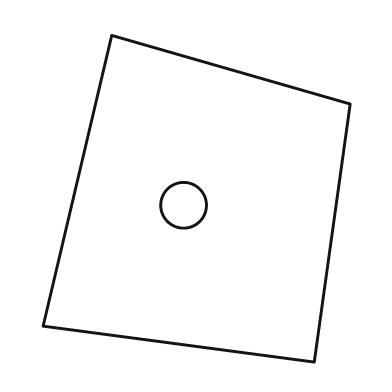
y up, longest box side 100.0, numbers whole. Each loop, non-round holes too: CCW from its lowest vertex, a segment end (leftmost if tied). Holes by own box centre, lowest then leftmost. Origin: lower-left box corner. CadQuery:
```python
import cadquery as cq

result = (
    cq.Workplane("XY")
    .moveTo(83.0, 0.0)
    .lineTo(94.0, 79.0)
    .lineTo(21.0, 100.0)
    .lineTo(0.0, 11.0)
    .close()
    .moveTo(43.0, 48.0)
    .circle(7.0)
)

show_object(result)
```